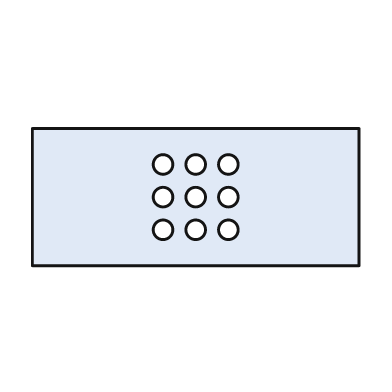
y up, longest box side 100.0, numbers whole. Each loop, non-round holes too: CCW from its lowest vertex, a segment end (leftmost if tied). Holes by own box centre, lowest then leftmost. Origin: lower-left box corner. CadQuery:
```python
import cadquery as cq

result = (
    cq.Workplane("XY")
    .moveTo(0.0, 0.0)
    .lineTo(100.0, 0.0)
    .lineTo(100.0, 42.0)
    .lineTo(0.0, 42.0)
    .close()
    .moveTo(40.0, 11.0)
    .circle(3.0)
    .moveTo(50.0, 11.0)
    .circle(3.0)
    .moveTo(60.0, 11.0)
    .circle(3.0)
    .moveTo(40.0, 21.0)
    .circle(3.0)
    .moveTo(50.0, 21.0)
    .circle(3.0)
    .moveTo(60.0, 21.0)
    .circle(3.0)
    .moveTo(40.0, 31.0)
    .circle(3.0)
    .moveTo(50.0, 31.0)
    .circle(3.0)
    .moveTo(60.0, 31.0)
    .circle(3.0)
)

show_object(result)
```